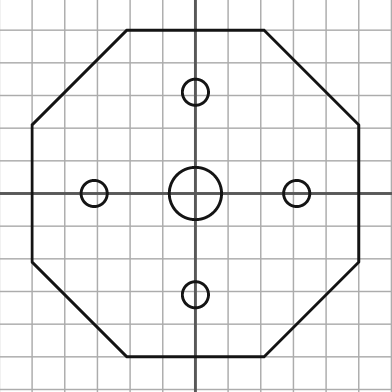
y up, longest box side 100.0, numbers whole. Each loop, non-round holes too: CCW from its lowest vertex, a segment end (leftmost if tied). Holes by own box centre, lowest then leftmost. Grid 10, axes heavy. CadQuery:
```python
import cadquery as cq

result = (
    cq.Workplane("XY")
    .moveTo(-21.0, -50.0)
    .lineTo(21.0, -50.0)
    .lineTo(50.0, -21.0)
    .lineTo(50.0, 21.0)
    .lineTo(21.0, 50.0)
    .lineTo(-21.0, 50.0)
    .lineTo(-50.0, 21.0)
    .lineTo(-50.0, -21.0)
    .close()
    .moveTo(0.0, -31.0)
    .circle(4.0)
    .moveTo(-31.0, 0.0)
    .circle(4.0)
    .moveTo(0.0, 0.0)
    .circle(8.0)
    .moveTo(31.0, 0.0)
    .circle(4.0)
    .moveTo(0.0, 31.0)
    .circle(4.0)
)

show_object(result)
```